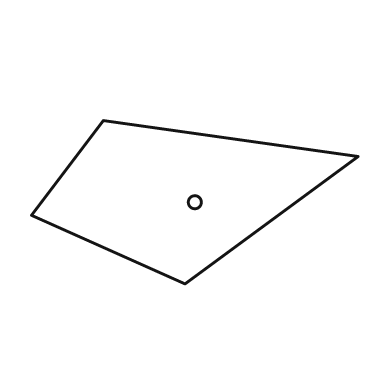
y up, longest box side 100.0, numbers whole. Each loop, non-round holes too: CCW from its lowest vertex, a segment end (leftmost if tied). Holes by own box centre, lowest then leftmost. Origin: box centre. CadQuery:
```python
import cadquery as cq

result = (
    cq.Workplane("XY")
    .moveTo(-3.0, -25.0)
    .lineTo(50.0, 14.0)
    .lineTo(-28.0, 25.0)
    .lineTo(-50.0, -4.0)
    .close()
    .moveTo(0.0, 0.0)
    .circle(2.0)
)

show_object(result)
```